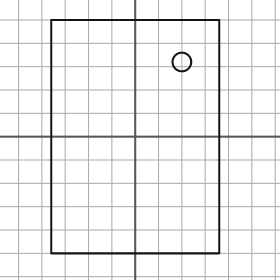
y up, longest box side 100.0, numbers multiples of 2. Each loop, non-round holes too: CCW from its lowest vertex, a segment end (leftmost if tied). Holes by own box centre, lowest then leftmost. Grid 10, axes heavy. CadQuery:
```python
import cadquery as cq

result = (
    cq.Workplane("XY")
    .moveTo(-36.0, -50.0)
    .lineTo(36.0, -50.0)
    .lineTo(36.0, 50.0)
    .lineTo(-36.0, 50.0)
    .close()
    .moveTo(20.0, 32.0)
    .circle(4.0)
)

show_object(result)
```